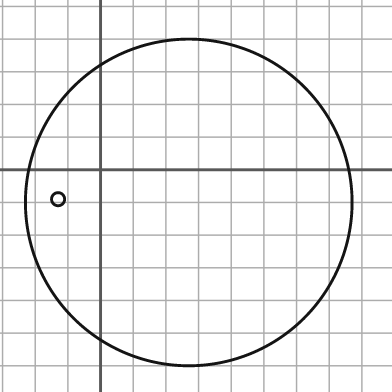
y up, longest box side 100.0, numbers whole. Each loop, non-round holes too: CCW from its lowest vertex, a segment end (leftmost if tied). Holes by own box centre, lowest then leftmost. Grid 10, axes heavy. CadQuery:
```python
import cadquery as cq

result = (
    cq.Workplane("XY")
    .moveTo(27.0, -10.0)
    .circle(50.0)
    .moveTo(-13.0, -9.0)
    .circle(2.0)
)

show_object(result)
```